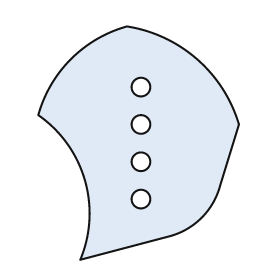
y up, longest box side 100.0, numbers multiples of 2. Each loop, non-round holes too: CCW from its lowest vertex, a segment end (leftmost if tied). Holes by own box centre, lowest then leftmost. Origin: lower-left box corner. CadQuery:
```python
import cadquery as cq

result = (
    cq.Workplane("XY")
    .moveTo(18.0, 0.0)
    .lineTo(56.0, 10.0)
    .threePointArc((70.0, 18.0), (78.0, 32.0))
    .lineTo(86.0, 58.0)
    .threePointArc((68.0, 86.0), (38.0, 100.0))
    .threePointArc((14.0, 86.0), (0.0, 62.0))
    .threePointArc((20.0, 34.0), (18.0, 0.0))
    .close()
    .moveTo(44.0, 26.0)
    .circle(4.0)
    .moveTo(44.0, 42.0)
    .circle(4.0)
    .moveTo(44.0, 58.0)
    .circle(4.0)
    .moveTo(44.0, 74.0)
    .circle(4.0)
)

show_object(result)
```